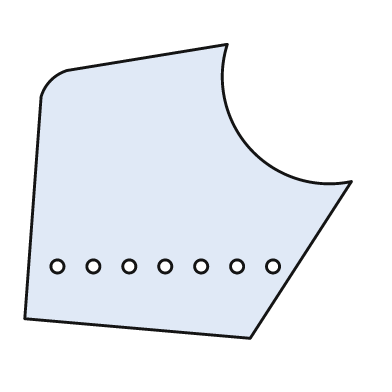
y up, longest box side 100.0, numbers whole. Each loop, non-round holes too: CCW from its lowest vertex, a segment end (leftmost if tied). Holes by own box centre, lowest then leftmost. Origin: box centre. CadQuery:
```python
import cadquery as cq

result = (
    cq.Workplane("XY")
    .moveTo(19.0, -45.0)
    .lineTo(50.0, 3.0)
    .threePointArc((19.0, 13.0), (12.0, 45.0))
    .lineTo(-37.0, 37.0)
    .threePointArc((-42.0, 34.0), (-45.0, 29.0))
    .lineTo(-50.0, -39.0)
    .close()
    .moveTo(-40.0, -23.0)
    .circle(2.0)
    .moveTo(-29.0, -23.0)
    .circle(2.0)
    .moveTo(-18.0, -23.0)
    .circle(2.0)
    .moveTo(-7.0, -23.0)
    .circle(2.0)
    .moveTo(4.0, -23.0)
    .circle(2.0)
    .moveTo(15.0, -23.0)
    .circle(2.0)
    .moveTo(26.0, -23.0)
    .circle(2.0)
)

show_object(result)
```